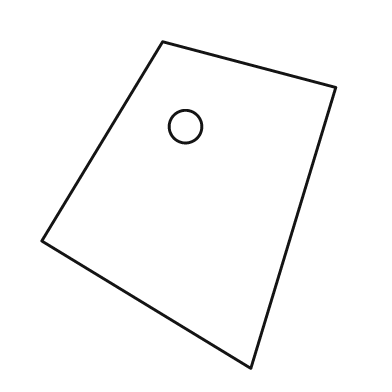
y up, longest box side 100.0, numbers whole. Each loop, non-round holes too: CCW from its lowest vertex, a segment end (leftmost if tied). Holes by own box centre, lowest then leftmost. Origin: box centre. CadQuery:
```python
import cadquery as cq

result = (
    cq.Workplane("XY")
    .moveTo(19.0, -50.0)
    .lineTo(45.0, 36.0)
    .lineTo(-8.0, 50.0)
    .lineTo(-45.0, -11.0)
    .close()
    .moveTo(-1.0, 24.0)
    .circle(5.0)
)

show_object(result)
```